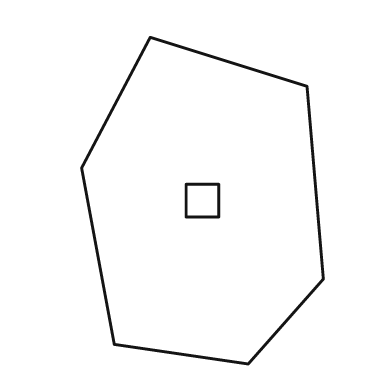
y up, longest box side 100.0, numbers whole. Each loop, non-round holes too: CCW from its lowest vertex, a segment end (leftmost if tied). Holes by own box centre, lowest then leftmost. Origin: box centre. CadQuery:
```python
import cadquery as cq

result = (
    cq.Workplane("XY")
    .moveTo(14.0, -50.0)
    .lineTo(37.0, -24.0)
    .lineTo(32.0, 35.0)
    .lineTo(-16.0, 50.0)
    .lineTo(-37.0, 10.0)
    .lineTo(-27.0, -44.0)
    .close()
    .moveTo(-5.0, -5.0)
    .lineTo(5.0, -5.0)
    .lineTo(5.0, 5.0)
    .lineTo(-5.0, 5.0)
    .close()
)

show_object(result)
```